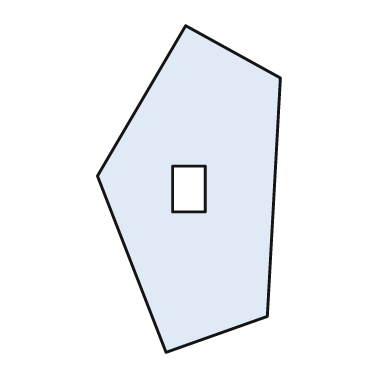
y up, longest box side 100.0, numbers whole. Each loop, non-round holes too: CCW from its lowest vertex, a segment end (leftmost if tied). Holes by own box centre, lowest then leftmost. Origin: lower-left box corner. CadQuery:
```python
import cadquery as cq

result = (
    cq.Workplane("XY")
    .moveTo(21.0, 0.0)
    .lineTo(52.0, 11.0)
    .lineTo(56.0, 84.0)
    .lineTo(27.0, 100.0)
    .lineTo(0.0, 54.0)
    .close()
    .moveTo(23.0, 43.0)
    .lineTo(33.0, 43.0)
    .lineTo(33.0, 57.0)
    .lineTo(23.0, 57.0)
    .close()
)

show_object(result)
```